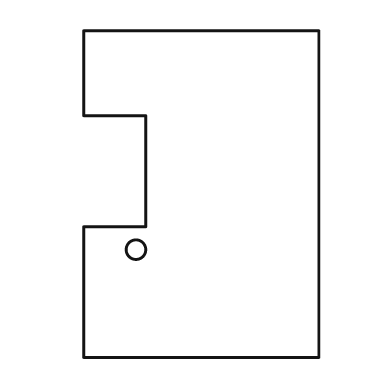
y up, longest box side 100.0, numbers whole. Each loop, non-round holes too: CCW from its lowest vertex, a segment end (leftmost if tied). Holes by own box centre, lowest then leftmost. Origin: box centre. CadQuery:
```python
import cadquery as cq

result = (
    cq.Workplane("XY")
    .moveTo(-36.0, -50.0)
    .lineTo(36.0, -50.0)
    .lineTo(36.0, 50.0)
    .lineTo(-36.0, 50.0)
    .lineTo(-36.0, 24.0)
    .lineTo(-17.0, 24.0)
    .lineTo(-17.0, -10.0)
    .lineTo(-36.0, -10.0)
    .close()
    .moveTo(-20.0, -17.0)
    .circle(3.0)
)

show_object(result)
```